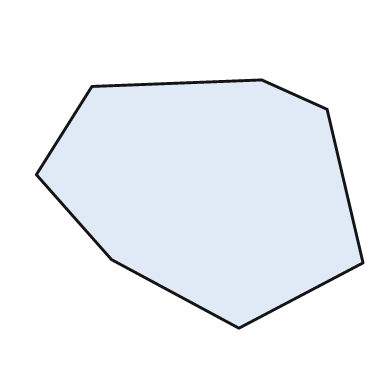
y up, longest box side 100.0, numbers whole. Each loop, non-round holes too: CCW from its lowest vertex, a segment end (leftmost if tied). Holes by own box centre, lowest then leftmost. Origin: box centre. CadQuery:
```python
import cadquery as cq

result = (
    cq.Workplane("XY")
    .moveTo(12.0, -38.0)
    .lineTo(50.0, -18.0)
    .lineTo(39.0, 29.0)
    .lineTo(19.0, 38.0)
    .lineTo(-33.0, 36.0)
    .lineTo(-50.0, 9.0)
    .lineTo(-27.0, -17.0)
    .close()
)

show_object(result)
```